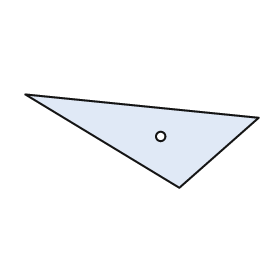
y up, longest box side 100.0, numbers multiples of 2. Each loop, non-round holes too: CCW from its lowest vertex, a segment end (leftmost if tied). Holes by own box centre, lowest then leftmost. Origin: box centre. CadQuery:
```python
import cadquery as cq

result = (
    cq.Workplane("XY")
    .moveTo(16.0, -20.0)
    .lineTo(50.0, 10.0)
    .lineTo(-50.0, 20.0)
    .close()
    .moveTo(8.0, 2.0)
    .circle(2.0)
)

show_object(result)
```